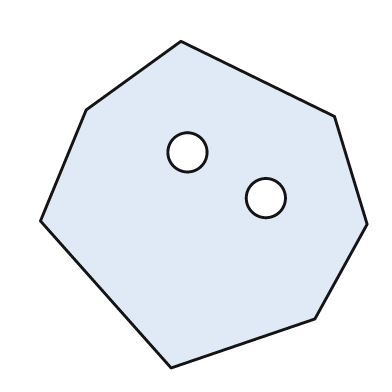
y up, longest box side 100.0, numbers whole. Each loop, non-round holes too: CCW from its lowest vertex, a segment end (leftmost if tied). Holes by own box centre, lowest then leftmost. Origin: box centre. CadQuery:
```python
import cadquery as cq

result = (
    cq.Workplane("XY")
    .moveTo(-10.0, -50.0)
    .lineTo(34.0, -35.0)
    .lineTo(50.0, -6.0)
    .lineTo(40.0, 27.0)
    .lineTo(-7.0, 50.0)
    .lineTo(-36.0, 29.0)
    .lineTo(-50.0, -5.0)
    .close()
    .moveTo(19.0, 2.0)
    .circle(6.0)
    .moveTo(-5.0, 16.0)
    .circle(6.0)
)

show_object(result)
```